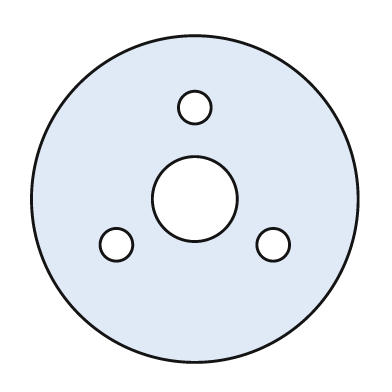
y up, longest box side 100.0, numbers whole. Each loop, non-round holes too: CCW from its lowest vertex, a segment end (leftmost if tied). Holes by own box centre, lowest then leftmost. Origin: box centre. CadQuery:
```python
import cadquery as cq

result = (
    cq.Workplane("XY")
    .moveTo(0.0, 0.0)
    .circle(50.0)
    .moveTo(-24.0, -14.0)
    .circle(5.0)
    .moveTo(24.0, -14.0)
    .circle(5.0)
    .moveTo(0.0, 0.0)
    .circle(13.0)
    .moveTo(0.0, 28.0)
    .circle(5.0)
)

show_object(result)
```